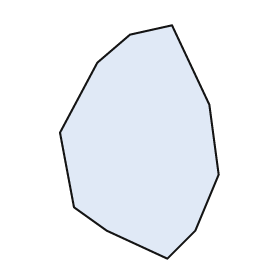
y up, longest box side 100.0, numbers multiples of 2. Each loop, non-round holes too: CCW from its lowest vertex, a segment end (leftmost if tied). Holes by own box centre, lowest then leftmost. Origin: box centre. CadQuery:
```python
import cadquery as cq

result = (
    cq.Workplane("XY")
    .moveTo(12.0, -50.0)
    .lineTo(24.0, -38.0)
    .lineTo(34.0, -14.0)
    .lineTo(30.0, 16.0)
    .lineTo(14.0, 50.0)
    .lineTo(-4.0, 46.0)
    .lineTo(-18.0, 34.0)
    .lineTo(-34.0, 4.0)
    .lineTo(-28.0, -28.0)
    .lineTo(-14.0, -38.0)
    .close()
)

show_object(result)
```